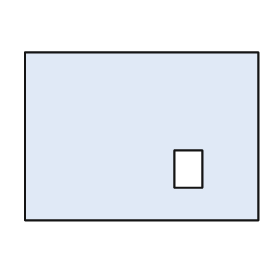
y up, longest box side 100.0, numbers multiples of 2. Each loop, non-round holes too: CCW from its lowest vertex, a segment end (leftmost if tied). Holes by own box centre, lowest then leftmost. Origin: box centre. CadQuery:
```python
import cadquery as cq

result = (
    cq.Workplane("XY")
    .moveTo(-50.0, -36.0)
    .lineTo(50.0, -36.0)
    .lineTo(50.0, 36.0)
    .lineTo(-50.0, 36.0)
    .close()
    .moveTo(14.0, -22.0)
    .lineTo(26.0, -22.0)
    .lineTo(26.0, -6.0)
    .lineTo(14.0, -6.0)
    .close()
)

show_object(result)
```